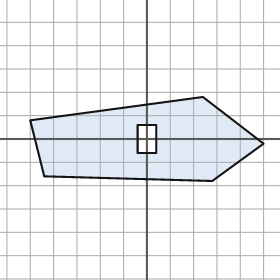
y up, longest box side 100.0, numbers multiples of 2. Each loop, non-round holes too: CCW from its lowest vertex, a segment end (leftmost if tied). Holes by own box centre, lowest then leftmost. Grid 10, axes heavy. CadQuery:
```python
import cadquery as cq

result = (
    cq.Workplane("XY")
    .moveTo(28.0, -18.0)
    .lineTo(50.0, -2.0)
    .lineTo(24.0, 18.0)
    .lineTo(-50.0, 8.0)
    .lineTo(-44.0, -16.0)
    .close()
    .moveTo(-4.0, -6.0)
    .lineTo(4.0, -6.0)
    .lineTo(4.0, 6.0)
    .lineTo(-4.0, 6.0)
    .close()
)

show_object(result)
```